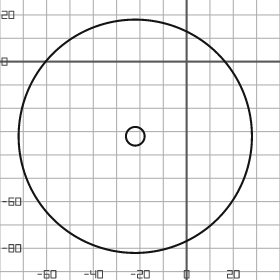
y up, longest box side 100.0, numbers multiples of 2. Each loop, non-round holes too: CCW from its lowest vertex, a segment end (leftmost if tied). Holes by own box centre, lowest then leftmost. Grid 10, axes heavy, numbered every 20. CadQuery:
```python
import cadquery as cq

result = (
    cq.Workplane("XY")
    .moveTo(-22.0, -32.0)
    .circle(50.0)
    .moveTo(-22.0, -32.0)
    .circle(4.0)
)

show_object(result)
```